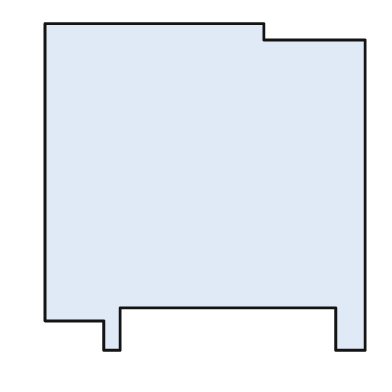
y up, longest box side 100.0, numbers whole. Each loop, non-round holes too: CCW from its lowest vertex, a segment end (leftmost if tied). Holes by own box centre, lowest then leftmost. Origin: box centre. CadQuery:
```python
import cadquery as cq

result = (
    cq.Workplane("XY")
    .moveTo(-31.0, -50.0)
    .lineTo(-26.0, -50.0)
    .lineTo(-26.0, -37.0)
    .lineTo(40.0, -37.0)
    .lineTo(40.0, -50.0)
    .lineTo(49.0, -50.0)
    .lineTo(49.0, 45.0)
    .lineTo(18.0, 45.0)
    .lineTo(18.0, 50.0)
    .lineTo(-49.0, 50.0)
    .lineTo(-49.0, -41.0)
    .lineTo(-31.0, -41.0)
    .close()
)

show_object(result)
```